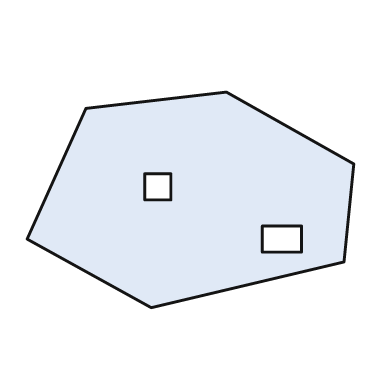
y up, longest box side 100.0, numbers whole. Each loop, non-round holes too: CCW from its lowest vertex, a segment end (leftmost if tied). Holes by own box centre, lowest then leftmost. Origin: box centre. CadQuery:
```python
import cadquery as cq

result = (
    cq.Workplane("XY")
    .moveTo(-12.0, -33.0)
    .lineTo(47.0, -19.0)
    .lineTo(50.0, 11.0)
    .lineTo(11.0, 33.0)
    .lineTo(-32.0, 28.0)
    .lineTo(-50.0, -12.0)
    .close()
    .moveTo(22.0, -16.0)
    .lineTo(34.0, -16.0)
    .lineTo(34.0, -8.0)
    .lineTo(22.0, -8.0)
    .close()
    .moveTo(-14.0, 0.0)
    .lineTo(-6.0, 0.0)
    .lineTo(-6.0, 8.0)
    .lineTo(-14.0, 8.0)
    .close()
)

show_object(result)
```